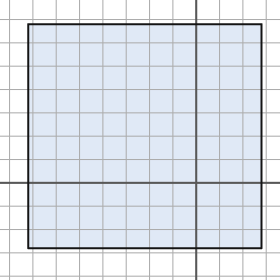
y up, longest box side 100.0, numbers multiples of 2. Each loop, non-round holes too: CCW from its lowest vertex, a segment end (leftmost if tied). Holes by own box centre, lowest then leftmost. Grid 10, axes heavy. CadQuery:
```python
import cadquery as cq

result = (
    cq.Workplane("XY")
    .moveTo(-72.0, -28.0)
    .lineTo(28.0, -28.0)
    .lineTo(28.0, 68.0)
    .lineTo(-72.0, 68.0)
    .close()
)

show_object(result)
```